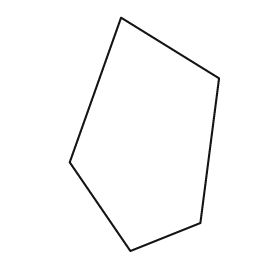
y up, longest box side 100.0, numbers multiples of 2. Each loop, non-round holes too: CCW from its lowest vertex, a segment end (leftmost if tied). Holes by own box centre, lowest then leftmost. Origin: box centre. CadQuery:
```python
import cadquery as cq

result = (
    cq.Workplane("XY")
    .moveTo(-6.0, -50.0)
    .lineTo(24.0, -38.0)
    .lineTo(32.0, 24.0)
    .lineTo(-10.0, 50.0)
    .lineTo(-32.0, -12.0)
    .close()
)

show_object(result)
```